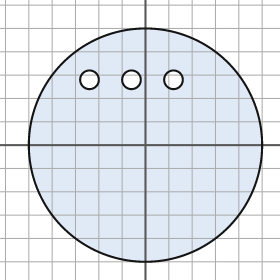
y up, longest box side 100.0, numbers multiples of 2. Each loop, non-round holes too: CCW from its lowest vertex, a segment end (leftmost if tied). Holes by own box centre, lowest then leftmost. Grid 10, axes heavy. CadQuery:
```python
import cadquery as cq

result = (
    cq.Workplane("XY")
    .moveTo(0.0, 0.0)
    .circle(50.0)
    .moveTo(-24.0, 28.0)
    .circle(4.0)
    .moveTo(-6.0, 28.0)
    .circle(4.0)
    .moveTo(12.0, 28.0)
    .circle(4.0)
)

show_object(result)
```